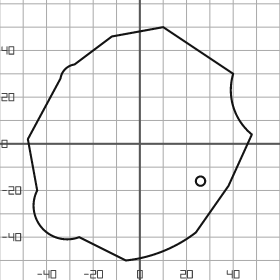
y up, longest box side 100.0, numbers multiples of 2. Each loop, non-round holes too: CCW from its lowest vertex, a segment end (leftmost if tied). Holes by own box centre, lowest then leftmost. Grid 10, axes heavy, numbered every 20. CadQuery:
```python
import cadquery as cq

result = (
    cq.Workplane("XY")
    .moveTo(-6.0, -50.0)
    .threePointArc((10.0, -46.0), (24.0, -38.0))
    .lineTo(38.0, -18.0)
    .lineTo(48.0, 4.0)
    .threePointArc((40.0, 16.0), (40.0, 30.0))
    .lineTo(10.0, 50.0)
    .lineTo(-12.0, 46.0)
    .lineTo(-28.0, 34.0)
    .threePointArc((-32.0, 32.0), (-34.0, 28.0))
    .lineTo(-48.0, 2.0)
    .lineTo(-44.0, -20.0)
    .threePointArc((-42.0, -36.0), (-26.0, -40.0))
    .close()
    .moveTo(26.0, -16.0)
    .circle(2.0)
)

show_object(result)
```